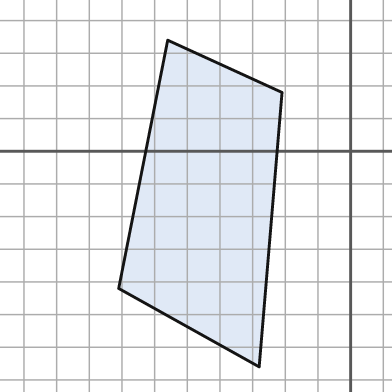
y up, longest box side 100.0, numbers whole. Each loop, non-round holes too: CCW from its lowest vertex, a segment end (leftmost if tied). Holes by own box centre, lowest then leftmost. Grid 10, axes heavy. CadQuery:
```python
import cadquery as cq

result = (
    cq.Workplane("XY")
    .moveTo(-28.0, -66.0)
    .lineTo(-21.0, 18.0)
    .lineTo(-56.0, 34.0)
    .lineTo(-71.0, -42.0)
    .close()
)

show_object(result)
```